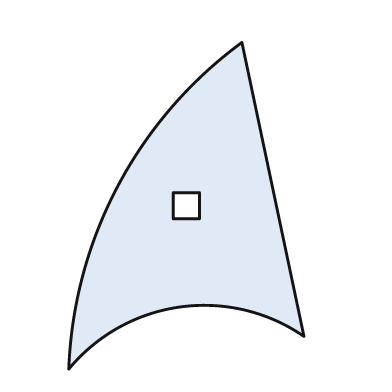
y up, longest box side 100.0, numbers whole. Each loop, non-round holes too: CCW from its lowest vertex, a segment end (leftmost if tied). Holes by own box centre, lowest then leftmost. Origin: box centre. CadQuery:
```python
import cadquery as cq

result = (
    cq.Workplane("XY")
    .moveTo(-36.0, -50.0)
    .threePointArc((-2.0, -31.0), (36.0, -40.0))
    .lineTo(17.0, 50.0)
    .threePointArc((-21.0, 6.0), (-36.0, -50.0))
    .close()
    .moveTo(-4.0, -4.0)
    .lineTo(4.0, -4.0)
    .lineTo(4.0, 4.0)
    .lineTo(-4.0, 4.0)
    .close()
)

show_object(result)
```